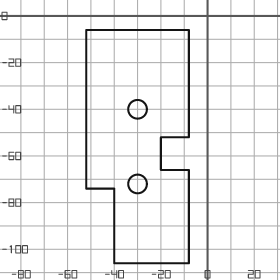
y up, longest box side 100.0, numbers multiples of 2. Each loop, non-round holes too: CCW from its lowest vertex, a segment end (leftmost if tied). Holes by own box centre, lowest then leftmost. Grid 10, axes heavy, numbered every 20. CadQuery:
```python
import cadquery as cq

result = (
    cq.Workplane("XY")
    .moveTo(-40.0, -106.0)
    .lineTo(-8.0, -106.0)
    .lineTo(-8.0, -66.0)
    .lineTo(-20.0, -66.0)
    .lineTo(-20.0, -52.0)
    .lineTo(-8.0, -52.0)
    .lineTo(-8.0, -6.0)
    .lineTo(-52.0, -6.0)
    .lineTo(-52.0, -74.0)
    .lineTo(-40.0, -74.0)
    .close()
    .moveTo(-30.0, -72.0)
    .circle(4.0)
    .moveTo(-30.0, -40.0)
    .circle(4.0)
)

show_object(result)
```